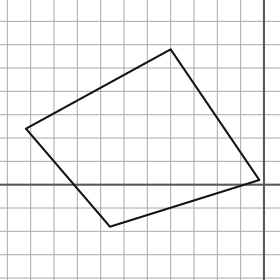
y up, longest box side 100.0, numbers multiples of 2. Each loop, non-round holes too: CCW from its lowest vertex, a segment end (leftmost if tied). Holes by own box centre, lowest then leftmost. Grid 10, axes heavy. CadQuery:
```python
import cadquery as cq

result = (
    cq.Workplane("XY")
    .moveTo(-66.0, -18.0)
    .lineTo(-2.0, 2.0)
    .lineTo(-40.0, 58.0)
    .lineTo(-102.0, 24.0)
    .close()
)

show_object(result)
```